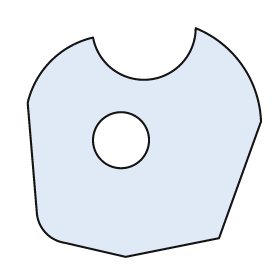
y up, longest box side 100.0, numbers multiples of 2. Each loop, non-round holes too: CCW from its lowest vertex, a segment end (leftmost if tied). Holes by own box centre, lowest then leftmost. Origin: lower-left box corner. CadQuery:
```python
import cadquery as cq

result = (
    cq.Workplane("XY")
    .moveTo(42.0, 0.0)
    .lineTo(82.0, 8.0)
    .lineTo(100.0, 58.0)
    .threePointArc((92.0, 82.0), (72.0, 98.0))
    .threePointArc((52.0, 76.0), (28.0, 94.0))
    .threePointArc((10.0, 84.0), (0.0, 66.0))
    .lineTo(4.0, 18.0)
    .threePointArc((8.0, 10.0), (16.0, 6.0))
    .close()
    .moveTo(40.0, 50.0)
    .circle(12.0)
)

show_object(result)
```